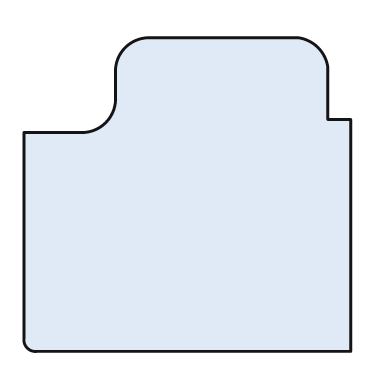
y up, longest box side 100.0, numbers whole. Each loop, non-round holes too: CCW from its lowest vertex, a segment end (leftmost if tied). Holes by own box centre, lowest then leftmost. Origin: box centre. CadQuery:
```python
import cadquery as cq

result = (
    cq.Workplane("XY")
    .moveTo(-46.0, -48.0)
    .lineTo(50.0, -48.0)
    .lineTo(50.0, 23.0)
    .lineTo(43.0, 23.0)
    .lineTo(43.0, 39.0)
    .threePointArc((40.0, 45.0), (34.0, 48.0))
    .lineTo(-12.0, 48.0)
    .threePointArc((-19.0, 45.0), (-22.0, 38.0))
    .lineTo(-22.0, 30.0)
    .threePointArc((-25.0, 22.0), (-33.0, 19.0))
    .lineTo(-50.0, 19.0)
    .lineTo(-50.0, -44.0)
    .threePointArc((-49.0, -47.0), (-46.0, -48.0))
    .close()
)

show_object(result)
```